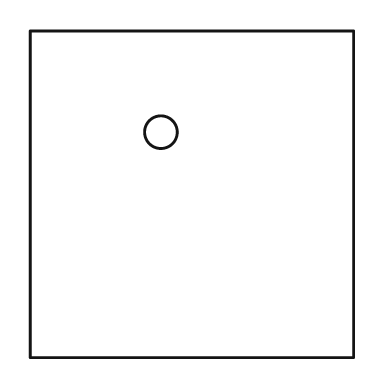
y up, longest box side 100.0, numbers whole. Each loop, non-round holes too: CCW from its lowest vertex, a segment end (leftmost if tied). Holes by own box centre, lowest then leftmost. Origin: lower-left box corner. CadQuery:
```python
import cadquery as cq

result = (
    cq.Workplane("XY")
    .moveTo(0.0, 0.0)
    .lineTo(99.0, 0.0)
    .lineTo(99.0, 100.0)
    .lineTo(0.0, 100.0)
    .close()
    .moveTo(40.0, 69.0)
    .circle(5.0)
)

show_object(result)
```